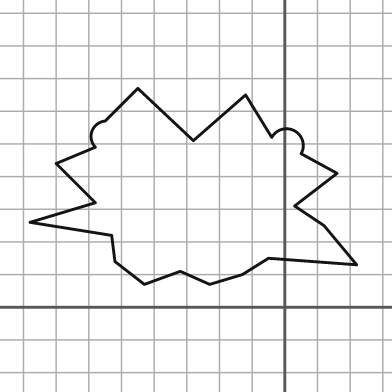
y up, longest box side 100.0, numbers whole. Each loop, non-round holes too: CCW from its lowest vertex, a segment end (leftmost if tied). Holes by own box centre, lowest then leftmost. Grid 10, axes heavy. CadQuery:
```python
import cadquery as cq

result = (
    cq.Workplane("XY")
    .moveTo(-43.0, 7.0)
    .lineTo(-32.0, 11.0)
    .lineTo(-23.0, 7.0)
    .lineTo(-13.0, 10.0)
    .lineTo(-5.0, 15.0)
    .lineTo(22.0, 13.0)
    .lineTo(12.0, 25.0)
    .lineTo(3.0, 31.0)
    .lineTo(16.0, 41.0)
    .lineTo(5.0, 47.0)
    .threePointArc((3.0, 54.0), (-4.0, 52.0))
    .lineTo(-12.0, 65.0)
    .lineTo(-28.0, 51.0)
    .lineTo(-45.0, 67.0)
    .lineTo(-55.0, 57.0)
    .threePointArc((-59.0, 54.0), (-58.0, 49.0))
    .lineTo(-70.0, 44.0)
    .lineTo(-58.0, 32.0)
    .lineTo(-78.0, 26.0)
    .lineTo(-53.0, 22.0)
    .lineTo(-52.0, 14.0)
    .close()
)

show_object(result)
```